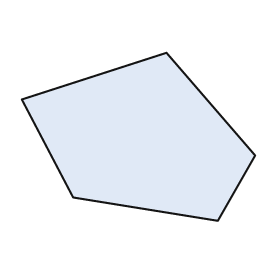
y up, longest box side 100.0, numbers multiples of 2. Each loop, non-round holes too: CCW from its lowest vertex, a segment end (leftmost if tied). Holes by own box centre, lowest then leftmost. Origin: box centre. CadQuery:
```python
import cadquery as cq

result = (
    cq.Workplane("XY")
    .moveTo(34.0, -36.0)
    .lineTo(50.0, -8.0)
    .lineTo(12.0, 36.0)
    .lineTo(-50.0, 16.0)
    .lineTo(-28.0, -26.0)
    .close()
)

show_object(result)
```